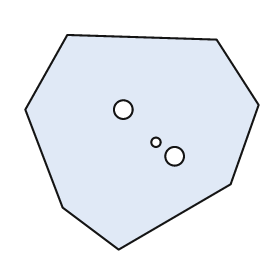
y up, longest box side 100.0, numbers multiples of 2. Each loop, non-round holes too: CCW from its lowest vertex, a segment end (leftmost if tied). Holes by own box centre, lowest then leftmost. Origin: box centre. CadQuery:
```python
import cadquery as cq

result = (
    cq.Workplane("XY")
    .moveTo(-10.0, -46.0)
    .lineTo(38.0, -18.0)
    .lineTo(50.0, 16.0)
    .lineTo(32.0, 44.0)
    .lineTo(-32.0, 46.0)
    .lineTo(-50.0, 14.0)
    .lineTo(-34.0, -28.0)
    .close()
    .moveTo(14.0, -6.0)
    .circle(4.0)
    .moveTo(6.0, 0.0)
    .circle(2.0)
    .moveTo(-8.0, 14.0)
    .circle(4.0)
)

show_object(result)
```